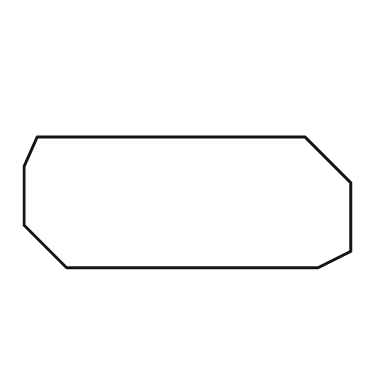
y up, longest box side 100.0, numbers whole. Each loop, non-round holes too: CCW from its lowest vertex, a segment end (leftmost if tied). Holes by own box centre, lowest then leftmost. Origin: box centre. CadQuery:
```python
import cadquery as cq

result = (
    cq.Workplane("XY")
    .moveTo(-37.0, -20.0)
    .lineTo(40.0, -20.0)
    .lineTo(50.0, -15.0)
    .lineTo(50.0, 6.0)
    .lineTo(36.0, 20.0)
    .lineTo(-46.0, 20.0)
    .lineTo(-50.0, 11.0)
    .lineTo(-50.0, -7.0)
    .close()
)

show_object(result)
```